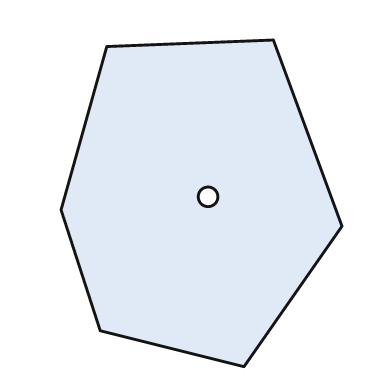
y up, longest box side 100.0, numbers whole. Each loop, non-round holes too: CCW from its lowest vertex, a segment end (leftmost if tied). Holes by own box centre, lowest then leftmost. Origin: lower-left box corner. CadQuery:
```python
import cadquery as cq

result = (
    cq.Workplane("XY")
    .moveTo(56.0, 0.0)
    .lineTo(86.0, 43.0)
    .lineTo(65.0, 100.0)
    .lineTo(14.0, 98.0)
    .lineTo(0.0, 48.0)
    .lineTo(12.0, 11.0)
    .close()
    .moveTo(45.0, 52.0)
    .circle(3.0)
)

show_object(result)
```